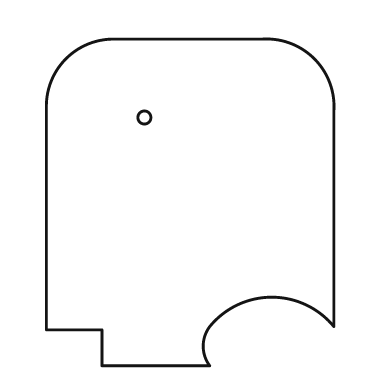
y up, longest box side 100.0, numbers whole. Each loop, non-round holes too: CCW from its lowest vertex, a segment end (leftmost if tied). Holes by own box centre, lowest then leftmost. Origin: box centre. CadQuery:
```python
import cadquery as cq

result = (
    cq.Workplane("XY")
    .moveTo(-27.0, -50.0)
    .lineTo(6.0, -50.0)
    .threePointArc((4.0, -44.0), (6.0, -38.0))
    .threePointArc((25.0, -29.0), (44.0, -38.0))
    .lineTo(44.0, 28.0)
    .threePointArc((38.0, 44.0), (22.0, 50.0))
    .lineTo(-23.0, 50.0)
    .threePointArc((-38.0, 44.0), (-44.0, 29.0))
    .lineTo(-44.0, -39.0)
    .lineTo(-27.0, -39.0)
    .close()
    .moveTo(-14.0, 26.0)
    .circle(2.0)
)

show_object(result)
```